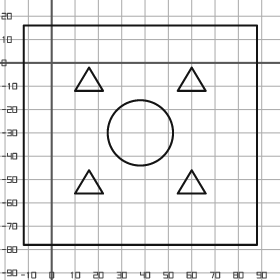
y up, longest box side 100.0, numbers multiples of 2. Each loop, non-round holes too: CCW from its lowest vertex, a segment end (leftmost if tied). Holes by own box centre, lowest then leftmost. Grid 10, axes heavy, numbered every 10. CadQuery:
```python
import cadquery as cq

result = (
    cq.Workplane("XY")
    .moveTo(-12.0, -78.0)
    .lineTo(88.0, -78.0)
    .lineTo(88.0, 16.0)
    .lineTo(-12.0, 16.0)
    .close()
    .moveTo(10.0, -56.0)
    .lineTo(22.0, -56.0)
    .lineTo(16.0, -46.0)
    .close()
    .moveTo(54.0, -56.0)
    .lineTo(66.0, -56.0)
    .lineTo(60.0, -46.0)
    .close()
    .moveTo(38.0, -30.0)
    .circle(14.0)
    .moveTo(10.0, -12.0)
    .lineTo(22.0, -12.0)
    .lineTo(16.0, -2.0)
    .close()
    .moveTo(54.0, -12.0)
    .lineTo(66.0, -12.0)
    .lineTo(60.0, -2.0)
    .close()
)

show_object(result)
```